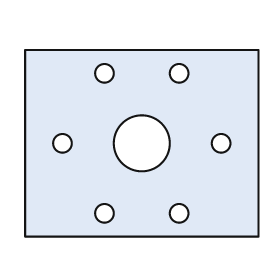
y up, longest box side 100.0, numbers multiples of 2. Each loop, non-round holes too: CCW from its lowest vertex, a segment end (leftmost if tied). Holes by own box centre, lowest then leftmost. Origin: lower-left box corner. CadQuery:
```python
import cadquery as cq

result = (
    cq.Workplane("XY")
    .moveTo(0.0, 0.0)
    .lineTo(100.0, 0.0)
    .lineTo(100.0, 80.0)
    .lineTo(0.0, 80.0)
    .close()
    .moveTo(34.0, 10.0)
    .circle(4.0)
    .moveTo(66.0, 10.0)
    .circle(4.0)
    .moveTo(16.0, 40.0)
    .circle(4.0)
    .moveTo(50.0, 40.0)
    .circle(12.0)
    .moveTo(84.0, 40.0)
    .circle(4.0)
    .moveTo(34.0, 70.0)
    .circle(4.0)
    .moveTo(66.0, 70.0)
    .circle(4.0)
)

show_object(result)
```